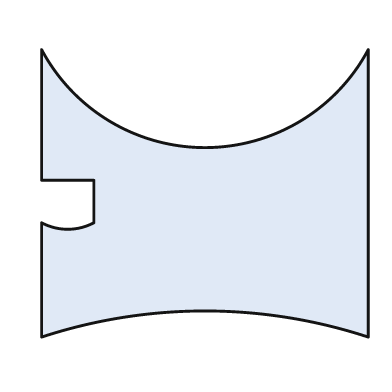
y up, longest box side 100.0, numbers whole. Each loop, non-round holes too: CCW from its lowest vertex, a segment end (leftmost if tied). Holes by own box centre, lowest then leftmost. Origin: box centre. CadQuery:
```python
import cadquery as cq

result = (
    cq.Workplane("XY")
    .moveTo(-50.0, -44.0)
    .threePointArc((0.0, -36.0), (50.0, -44.0))
    .lineTo(50.0, 44.0)
    .threePointArc((0.0, 14.0), (-50.0, 44.0))
    .lineTo(-50.0, 4.0)
    .lineTo(-34.0, 4.0)
    .lineTo(-34.0, -9.0)
    .threePointArc((-42.0, -11.0), (-50.0, -9.0))
    .close()
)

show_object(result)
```